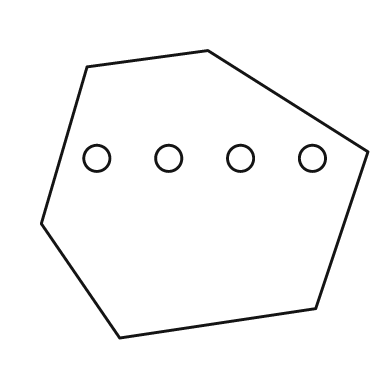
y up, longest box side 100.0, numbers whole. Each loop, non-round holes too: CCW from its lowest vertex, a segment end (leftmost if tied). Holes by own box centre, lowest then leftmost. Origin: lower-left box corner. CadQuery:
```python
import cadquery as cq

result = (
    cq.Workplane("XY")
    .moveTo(24.0, 0.0)
    .lineTo(84.0, 9.0)
    .lineTo(100.0, 57.0)
    .lineTo(51.0, 88.0)
    .lineTo(14.0, 83.0)
    .lineTo(0.0, 35.0)
    .close()
    .moveTo(17.0, 55.0)
    .circle(4.0)
    .moveTo(39.0, 55.0)
    .circle(4.0)
    .moveTo(61.0, 55.0)
    .circle(4.0)
    .moveTo(83.0, 55.0)
    .circle(4.0)
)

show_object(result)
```